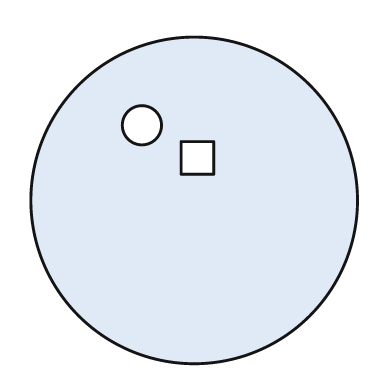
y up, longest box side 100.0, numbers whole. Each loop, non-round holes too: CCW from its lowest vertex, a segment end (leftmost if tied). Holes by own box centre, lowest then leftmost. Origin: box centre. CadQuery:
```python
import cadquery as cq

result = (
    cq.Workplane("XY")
    .moveTo(0.0, 0.0)
    .circle(50.0)
    .moveTo(-4.0, 8.0)
    .lineTo(6.0, 8.0)
    .lineTo(6.0, 18.0)
    .lineTo(-4.0, 18.0)
    .close()
    .moveTo(-16.0, 23.0)
    .circle(6.0)
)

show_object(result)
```